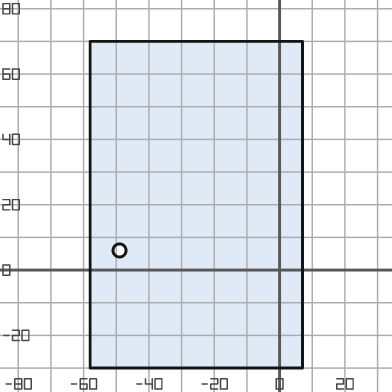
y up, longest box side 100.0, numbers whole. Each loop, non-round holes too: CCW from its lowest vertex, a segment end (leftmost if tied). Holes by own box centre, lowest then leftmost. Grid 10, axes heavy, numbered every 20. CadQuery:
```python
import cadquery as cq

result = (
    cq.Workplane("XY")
    .moveTo(-58.0, -30.0)
    .lineTo(7.0, -30.0)
    .lineTo(7.0, 70.0)
    .lineTo(-58.0, 70.0)
    .close()
    .moveTo(-49.0, 6.0)
    .circle(2.0)
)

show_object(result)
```